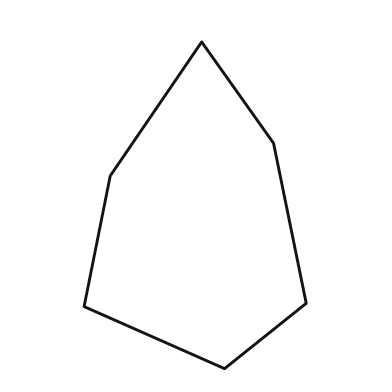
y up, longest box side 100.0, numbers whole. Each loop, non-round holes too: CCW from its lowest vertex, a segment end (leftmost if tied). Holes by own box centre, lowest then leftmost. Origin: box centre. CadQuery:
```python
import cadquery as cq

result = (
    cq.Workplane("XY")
    .moveTo(9.0, -50.0)
    .lineTo(34.0, -30.0)
    .lineTo(24.0, 19.0)
    .lineTo(2.0, 50.0)
    .lineTo(-26.0, 9.0)
    .lineTo(-34.0, -31.0)
    .close()
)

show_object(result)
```